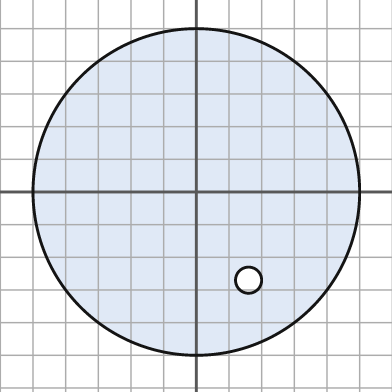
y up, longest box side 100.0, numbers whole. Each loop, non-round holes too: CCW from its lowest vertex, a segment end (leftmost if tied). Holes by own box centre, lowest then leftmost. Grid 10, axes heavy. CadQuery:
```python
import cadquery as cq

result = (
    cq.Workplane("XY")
    .moveTo(0.0, 0.0)
    .circle(50.0)
    .moveTo(16.0, -27.0)
    .circle(4.0)
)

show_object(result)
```